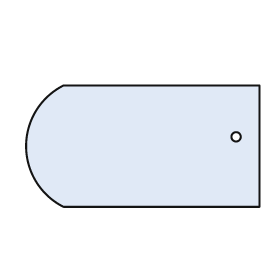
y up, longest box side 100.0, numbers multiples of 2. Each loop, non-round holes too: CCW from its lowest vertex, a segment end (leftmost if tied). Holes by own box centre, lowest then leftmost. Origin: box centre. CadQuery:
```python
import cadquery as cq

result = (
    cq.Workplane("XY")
    .moveTo(-34.0, -26.0)
    .lineTo(50.0, -26.0)
    .lineTo(50.0, 26.0)
    .lineTo(-34.0, 26.0)
    .threePointArc((-50.0, 0.0), (-34.0, -26.0))
    .close()
    .moveTo(40.0, 4.0)
    .circle(2.0)
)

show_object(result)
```